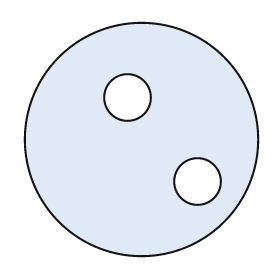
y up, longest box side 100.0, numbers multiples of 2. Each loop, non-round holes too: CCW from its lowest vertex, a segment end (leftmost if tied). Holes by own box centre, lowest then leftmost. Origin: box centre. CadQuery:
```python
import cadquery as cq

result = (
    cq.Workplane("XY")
    .moveTo(0.0, 0.0)
    .circle(50.0)
    .moveTo(24.0, -18.0)
    .circle(10.0)
    .moveTo(-6.0, 18.0)
    .circle(10.0)
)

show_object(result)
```